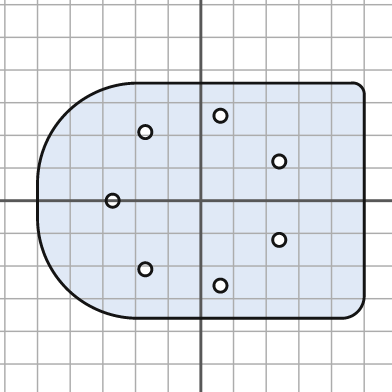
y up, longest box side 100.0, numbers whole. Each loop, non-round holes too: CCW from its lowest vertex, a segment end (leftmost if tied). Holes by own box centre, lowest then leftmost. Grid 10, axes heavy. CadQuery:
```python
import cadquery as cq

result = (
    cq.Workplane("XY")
    .moveTo(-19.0, -36.0)
    .lineTo(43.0, -36.0)
    .threePointArc((48.0, -34.0), (50.0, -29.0))
    .lineTo(50.0, 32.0)
    .threePointArc((49.0, 35.0), (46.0, 36.0))
    .lineTo(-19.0, 36.0)
    .threePointArc((-41.0, 27.0), (-50.0, 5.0))
    .lineTo(-50.0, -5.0)
    .threePointArc((-41.0, -27.0), (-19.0, -36.0))
    .close()
    .moveTo(6.0, -26.0)
    .circle(2.0)
    .moveTo(-17.0, -21.0)
    .circle(2.0)
    .moveTo(24.0, -12.0)
    .circle(2.0)
    .moveTo(-27.0, 0.0)
    .circle(2.0)
    .moveTo(24.0, 12.0)
    .circle(2.0)
    .moveTo(-17.0, 21.0)
    .circle(2.0)
    .moveTo(6.0, 26.0)
    .circle(2.0)
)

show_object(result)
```